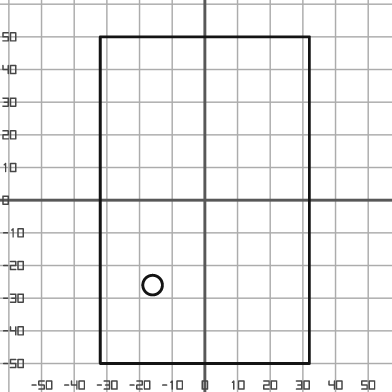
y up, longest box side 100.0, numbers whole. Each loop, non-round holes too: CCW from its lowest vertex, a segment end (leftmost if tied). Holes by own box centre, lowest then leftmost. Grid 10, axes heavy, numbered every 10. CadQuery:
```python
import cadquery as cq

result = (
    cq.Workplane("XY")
    .moveTo(-32.0, -50.0)
    .lineTo(32.0, -50.0)
    .lineTo(32.0, 50.0)
    .lineTo(-32.0, 50.0)
    .close()
    .moveTo(-16.0, -26.0)
    .circle(3.0)
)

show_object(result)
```